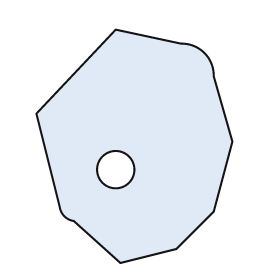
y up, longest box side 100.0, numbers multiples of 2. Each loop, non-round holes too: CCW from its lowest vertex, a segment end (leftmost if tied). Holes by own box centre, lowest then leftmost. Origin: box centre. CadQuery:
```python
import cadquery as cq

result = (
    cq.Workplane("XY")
    .moveTo(-6.0, -50.0)
    .lineTo(18.0, -44.0)
    .lineTo(34.0, -28.0)
    .lineTo(42.0, 2.0)
    .lineTo(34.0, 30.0)
    .threePointArc((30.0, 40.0), (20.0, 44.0))
    .lineTo(-8.0, 50.0)
    .lineTo(-42.0, 14.0)
    .lineTo(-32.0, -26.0)
    .threePointArc((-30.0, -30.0), (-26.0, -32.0))
    .close()
    .moveTo(-8.0, -10.0)
    .circle(8.0)
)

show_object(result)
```